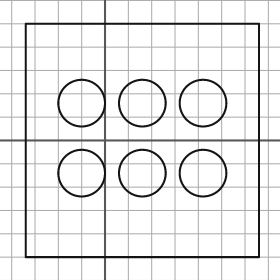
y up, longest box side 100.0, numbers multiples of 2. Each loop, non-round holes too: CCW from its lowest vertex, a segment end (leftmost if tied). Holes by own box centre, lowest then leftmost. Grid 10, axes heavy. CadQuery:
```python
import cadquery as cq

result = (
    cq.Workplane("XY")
    .moveTo(-34.0, -50.0)
    .lineTo(66.0, -50.0)
    .lineTo(66.0, 50.0)
    .lineTo(-34.0, 50.0)
    .close()
    .moveTo(-10.0, -14.0)
    .circle(10.0)
    .moveTo(16.0, -14.0)
    .circle(10.0)
    .moveTo(42.0, -14.0)
    .circle(10.0)
    .moveTo(-10.0, 16.0)
    .circle(10.0)
    .moveTo(16.0, 16.0)
    .circle(10.0)
    .moveTo(42.0, 16.0)
    .circle(10.0)
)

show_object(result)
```